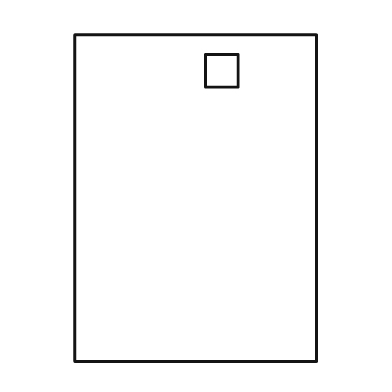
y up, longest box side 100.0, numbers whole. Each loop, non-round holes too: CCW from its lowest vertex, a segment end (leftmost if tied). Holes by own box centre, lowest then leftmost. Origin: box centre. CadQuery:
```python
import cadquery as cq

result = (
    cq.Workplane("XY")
    .moveTo(-37.0, -50.0)
    .lineTo(37.0, -50.0)
    .lineTo(37.0, 50.0)
    .lineTo(-37.0, 50.0)
    .close()
    .moveTo(3.0, 34.0)
    .lineTo(13.0, 34.0)
    .lineTo(13.0, 44.0)
    .lineTo(3.0, 44.0)
    .close()
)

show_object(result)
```